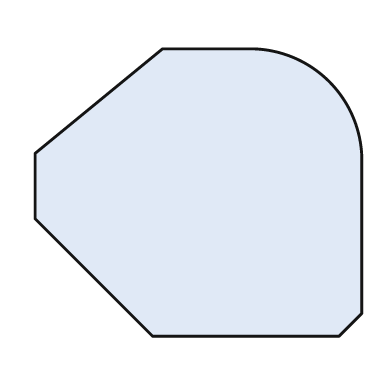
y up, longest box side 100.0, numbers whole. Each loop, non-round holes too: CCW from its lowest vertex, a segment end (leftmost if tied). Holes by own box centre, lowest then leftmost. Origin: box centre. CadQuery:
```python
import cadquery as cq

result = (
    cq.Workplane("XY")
    .moveTo(-14.0, -44.0)
    .lineTo(43.0, -44.0)
    .lineTo(50.0, -37.0)
    .lineTo(50.0, 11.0)
    .threePointArc((40.0, 34.0), (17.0, 44.0))
    .lineTo(-11.0, 44.0)
    .lineTo(-50.0, 12.0)
    .lineTo(-50.0, -8.0)
    .close()
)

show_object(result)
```